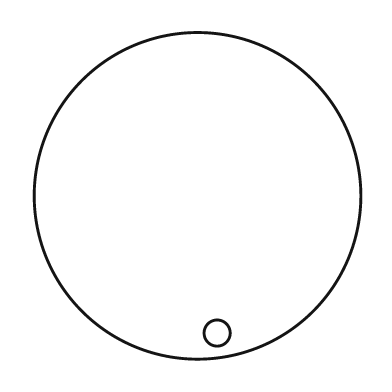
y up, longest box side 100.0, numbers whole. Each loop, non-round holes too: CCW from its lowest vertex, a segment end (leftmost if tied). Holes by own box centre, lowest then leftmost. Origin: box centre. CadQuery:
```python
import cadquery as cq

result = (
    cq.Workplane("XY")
    .moveTo(0.0, 0.0)
    .circle(50.0)
    .moveTo(6.0, -42.0)
    .circle(4.0)
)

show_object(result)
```